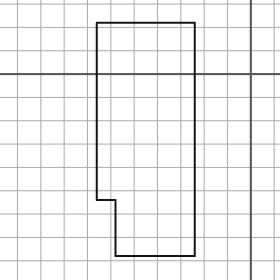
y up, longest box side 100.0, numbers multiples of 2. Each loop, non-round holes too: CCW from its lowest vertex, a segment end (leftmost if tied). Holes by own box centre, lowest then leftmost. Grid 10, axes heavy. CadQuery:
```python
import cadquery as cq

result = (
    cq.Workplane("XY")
    .moveTo(-58.0, -78.0)
    .lineTo(-24.0, -78.0)
    .lineTo(-24.0, 22.0)
    .lineTo(-66.0, 22.0)
    .lineTo(-66.0, -54.0)
    .lineTo(-58.0, -54.0)
    .close()
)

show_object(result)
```